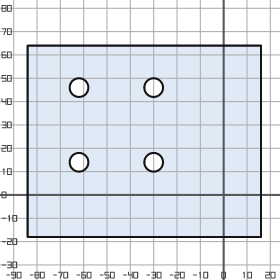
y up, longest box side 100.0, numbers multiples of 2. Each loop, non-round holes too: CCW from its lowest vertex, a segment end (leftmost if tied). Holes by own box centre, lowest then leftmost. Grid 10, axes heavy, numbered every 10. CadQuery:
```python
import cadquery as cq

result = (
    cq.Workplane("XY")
    .moveTo(-84.0, -18.0)
    .lineTo(16.0, -18.0)
    .lineTo(16.0, 64.0)
    .lineTo(-84.0, 64.0)
    .close()
    .moveTo(-62.0, 14.0)
    .circle(4.0)
    .moveTo(-30.0, 14.0)
    .circle(4.0)
    .moveTo(-62.0, 46.0)
    .circle(4.0)
    .moveTo(-30.0, 46.0)
    .circle(4.0)
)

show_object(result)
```